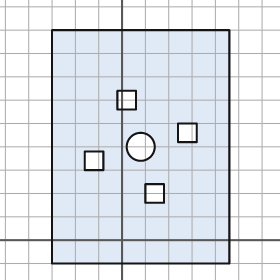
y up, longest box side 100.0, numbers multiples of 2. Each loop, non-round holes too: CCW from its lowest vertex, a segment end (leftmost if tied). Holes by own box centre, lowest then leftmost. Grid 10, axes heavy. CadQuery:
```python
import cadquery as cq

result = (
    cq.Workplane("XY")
    .moveTo(-30.0, -10.0)
    .lineTo(46.0, -10.0)
    .lineTo(46.0, 90.0)
    .lineTo(-30.0, 90.0)
    .close()
    .moveTo(10.0, 16.0)
    .lineTo(18.0, 16.0)
    .lineTo(18.0, 24.0)
    .lineTo(10.0, 24.0)
    .close()
    .moveTo(-16.0, 30.0)
    .lineTo(-8.0, 30.0)
    .lineTo(-8.0, 38.0)
    .lineTo(-16.0, 38.0)
    .close()
    .moveTo(8.0, 40.0)
    .circle(6.0)
    .moveTo(24.0, 42.0)
    .lineTo(32.0, 42.0)
    .lineTo(32.0, 50.0)
    .lineTo(24.0, 50.0)
    .close()
    .moveTo(-2.0, 56.0)
    .lineTo(6.0, 56.0)
    .lineTo(6.0, 64.0)
    .lineTo(-2.0, 64.0)
    .close()
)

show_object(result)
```